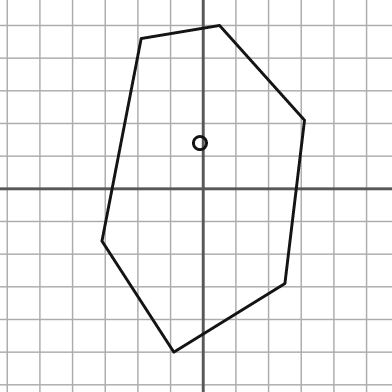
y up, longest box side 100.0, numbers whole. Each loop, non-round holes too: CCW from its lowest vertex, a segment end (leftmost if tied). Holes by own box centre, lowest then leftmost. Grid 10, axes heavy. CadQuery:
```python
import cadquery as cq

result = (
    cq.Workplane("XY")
    .moveTo(-9.0, -50.0)
    .lineTo(25.0, -29.0)
    .lineTo(31.0, 21.0)
    .lineTo(5.0, 50.0)
    .lineTo(-19.0, 46.0)
    .lineTo(-31.0, -16.0)
    .close()
    .moveTo(-1.0, 14.0)
    .circle(2.0)
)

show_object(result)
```